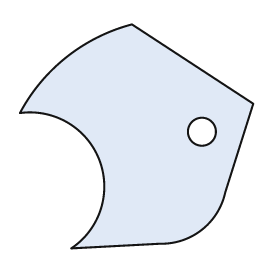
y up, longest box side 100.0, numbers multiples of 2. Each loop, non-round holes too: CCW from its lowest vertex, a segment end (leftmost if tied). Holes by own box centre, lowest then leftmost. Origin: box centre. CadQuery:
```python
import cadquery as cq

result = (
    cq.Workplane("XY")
    .moveTo(-28.0, -48.0)
    .lineTo(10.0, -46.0)
    .threePointArc((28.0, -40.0), (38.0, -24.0))
    .lineTo(50.0, 14.0)
    .lineTo(-2.0, 48.0)
    .threePointArc((-30.0, 34.0), (-50.0, 10.0))
    .threePointArc((-16.0, -10.0), (-28.0, -48.0))
    .close()
    .moveTo(28.0, 2.0)
    .circle(6.0)
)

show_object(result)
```